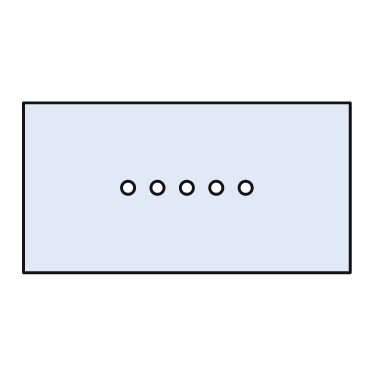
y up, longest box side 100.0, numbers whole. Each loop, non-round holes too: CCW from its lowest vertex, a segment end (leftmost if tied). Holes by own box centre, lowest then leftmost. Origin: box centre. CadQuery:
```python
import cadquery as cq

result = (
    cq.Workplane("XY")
    .moveTo(-50.0, -26.0)
    .lineTo(50.0, -26.0)
    .lineTo(50.0, 26.0)
    .lineTo(-50.0, 26.0)
    .close()
    .moveTo(-18.0, 0.0)
    .circle(2.0)
    .moveTo(-9.0, 0.0)
    .circle(2.0)
    .moveTo(0.0, 0.0)
    .circle(2.0)
    .moveTo(9.0, 0.0)
    .circle(2.0)
    .moveTo(18.0, 0.0)
    .circle(2.0)
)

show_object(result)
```